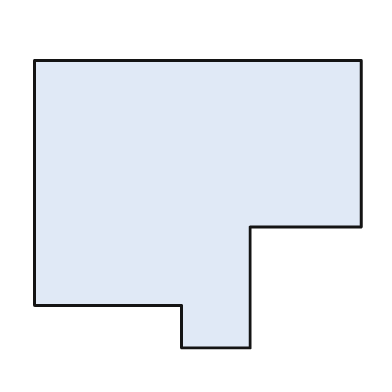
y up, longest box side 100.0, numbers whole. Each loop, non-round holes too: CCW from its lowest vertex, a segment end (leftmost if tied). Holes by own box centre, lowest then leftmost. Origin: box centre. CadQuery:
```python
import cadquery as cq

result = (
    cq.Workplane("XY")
    .moveTo(-5.0, -44.0)
    .lineTo(16.0, -44.0)
    .lineTo(16.0, -7.0)
    .lineTo(50.0, -7.0)
    .lineTo(50.0, 44.0)
    .lineTo(-50.0, 44.0)
    .lineTo(-50.0, -31.0)
    .lineTo(-5.0, -31.0)
    .close()
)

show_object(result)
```